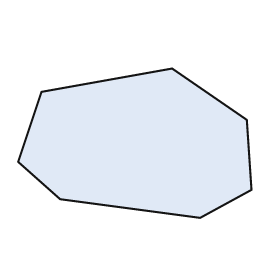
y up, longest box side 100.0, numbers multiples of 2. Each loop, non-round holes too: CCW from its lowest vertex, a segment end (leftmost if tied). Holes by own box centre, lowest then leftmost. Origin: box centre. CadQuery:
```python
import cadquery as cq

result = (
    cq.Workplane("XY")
    .moveTo(28.0, -32.0)
    .lineTo(50.0, -20.0)
    .lineTo(48.0, 10.0)
    .lineTo(16.0, 32.0)
    .lineTo(-40.0, 22.0)
    .lineTo(-50.0, -8.0)
    .lineTo(-32.0, -24.0)
    .close()
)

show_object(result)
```